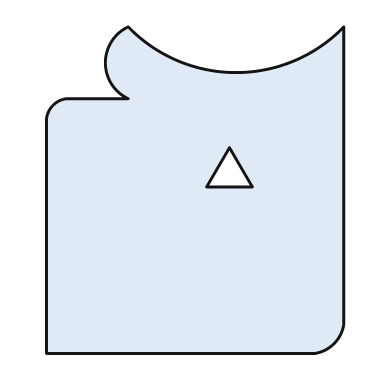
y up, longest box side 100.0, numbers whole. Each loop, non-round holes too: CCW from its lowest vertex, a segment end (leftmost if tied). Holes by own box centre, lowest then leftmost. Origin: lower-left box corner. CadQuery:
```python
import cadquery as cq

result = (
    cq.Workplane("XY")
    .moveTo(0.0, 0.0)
    .lineTo(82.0, 0.0)
    .threePointArc((88.0, 3.0), (91.0, 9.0))
    .lineTo(91.0, 100.0)
    .threePointArc((58.0, 86.0), (25.0, 100.0))
    .threePointArc((18.0, 89.0), (25.0, 78.0))
    .lineTo(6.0, 78.0)
    .threePointArc((2.0, 76.0), (0.0, 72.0))
    .close()
    .moveTo(49.0, 51.0)
    .lineTo(63.0, 51.0)
    .lineTo(56.0, 63.0)
    .close()
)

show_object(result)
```